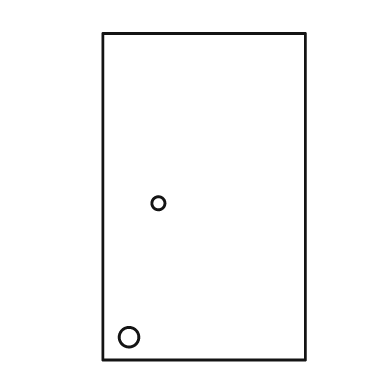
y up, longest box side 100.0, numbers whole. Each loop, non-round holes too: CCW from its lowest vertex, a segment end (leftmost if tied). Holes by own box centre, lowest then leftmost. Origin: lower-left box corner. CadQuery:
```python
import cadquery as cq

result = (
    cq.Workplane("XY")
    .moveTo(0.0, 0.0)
    .lineTo(62.0, 0.0)
    .lineTo(62.0, 100.0)
    .lineTo(0.0, 100.0)
    .close()
    .moveTo(8.0, 7.0)
    .circle(3.0)
    .moveTo(17.0, 48.0)
    .circle(2.0)
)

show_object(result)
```